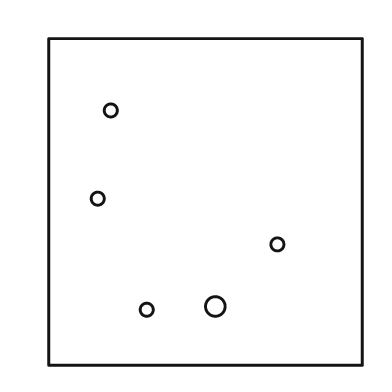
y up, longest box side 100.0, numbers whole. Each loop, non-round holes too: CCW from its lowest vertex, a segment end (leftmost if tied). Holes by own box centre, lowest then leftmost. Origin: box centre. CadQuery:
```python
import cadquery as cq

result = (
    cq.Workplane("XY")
    .moveTo(-48.0, -50.0)
    .lineTo(48.0, -50.0)
    .lineTo(48.0, 50.0)
    .lineTo(-48.0, 50.0)
    .close()
    .moveTo(-18.0, -33.0)
    .circle(2.0)
    .moveTo(3.0, -32.0)
    .circle(3.0)
    .moveTo(22.0, -13.0)
    .circle(2.0)
    .moveTo(-33.0, 1.0)
    .circle(2.0)
    .moveTo(-29.0, 28.0)
    .circle(2.0)
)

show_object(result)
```